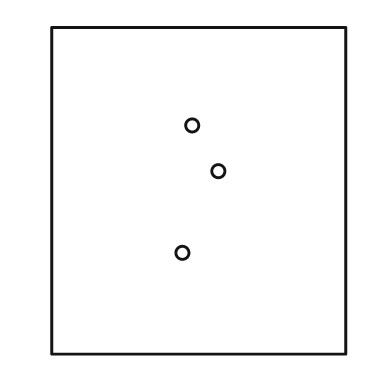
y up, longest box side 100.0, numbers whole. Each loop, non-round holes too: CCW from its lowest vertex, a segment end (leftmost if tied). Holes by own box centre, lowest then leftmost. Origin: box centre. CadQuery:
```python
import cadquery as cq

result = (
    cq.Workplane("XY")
    .moveTo(-45.0, -50.0)
    .lineTo(45.0, -50.0)
    .lineTo(45.0, 50.0)
    .lineTo(-45.0, 50.0)
    .close()
    .moveTo(-5.0, -19.0)
    .circle(2.0)
    .moveTo(6.0, 6.0)
    .circle(2.0)
    .moveTo(-2.0, 20.0)
    .circle(2.0)
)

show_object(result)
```